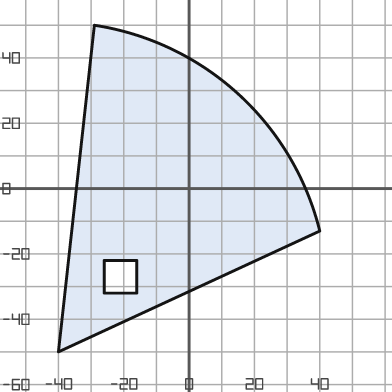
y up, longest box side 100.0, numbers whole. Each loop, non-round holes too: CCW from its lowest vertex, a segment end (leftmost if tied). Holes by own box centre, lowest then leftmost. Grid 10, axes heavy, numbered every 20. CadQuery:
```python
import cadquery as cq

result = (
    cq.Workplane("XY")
    .moveTo(-40.0, -50.0)
    .lineTo(40.0, -13.0)
    .threePointArc((15.0, 29.0), (-29.0, 50.0))
    .close()
    .moveTo(-26.0, -32.0)
    .lineTo(-16.0, -32.0)
    .lineTo(-16.0, -22.0)
    .lineTo(-26.0, -22.0)
    .close()
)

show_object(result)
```